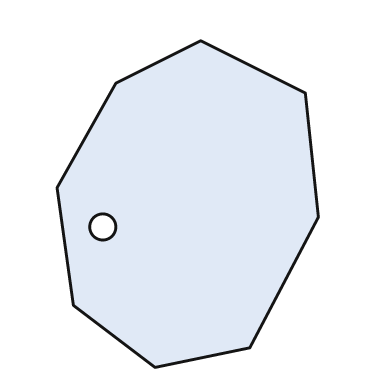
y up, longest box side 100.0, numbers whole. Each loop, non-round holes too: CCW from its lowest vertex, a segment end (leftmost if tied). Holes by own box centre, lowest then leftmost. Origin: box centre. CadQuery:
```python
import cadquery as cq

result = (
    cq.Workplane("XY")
    .moveTo(-10.0, -50.0)
    .lineTo(19.0, -44.0)
    .lineTo(40.0, -4.0)
    .lineTo(36.0, 34.0)
    .lineTo(4.0, 50.0)
    .lineTo(-22.0, 37.0)
    .lineTo(-40.0, 5.0)
    .lineTo(-35.0, -31.0)
    .close()
    .moveTo(-26.0, -7.0)
    .circle(4.0)
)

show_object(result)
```